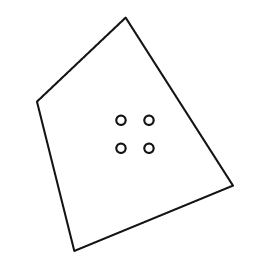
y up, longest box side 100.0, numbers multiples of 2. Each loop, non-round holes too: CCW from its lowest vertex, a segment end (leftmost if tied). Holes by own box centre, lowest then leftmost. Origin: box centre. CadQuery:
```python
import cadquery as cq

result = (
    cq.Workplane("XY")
    .moveTo(-26.0, -50.0)
    .lineTo(42.0, -22.0)
    .lineTo(-4.0, 50.0)
    .lineTo(-42.0, 14.0)
    .close()
    .moveTo(-6.0, -6.0)
    .circle(2.0)
    .moveTo(6.0, -6.0)
    .circle(2.0)
    .moveTo(-6.0, 6.0)
    .circle(2.0)
    .moveTo(6.0, 6.0)
    .circle(2.0)
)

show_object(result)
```